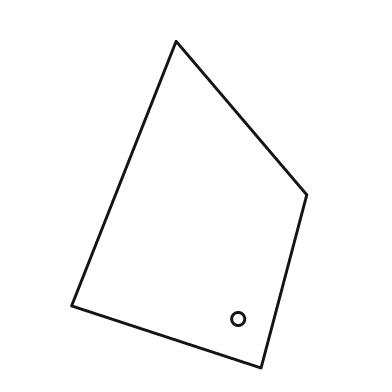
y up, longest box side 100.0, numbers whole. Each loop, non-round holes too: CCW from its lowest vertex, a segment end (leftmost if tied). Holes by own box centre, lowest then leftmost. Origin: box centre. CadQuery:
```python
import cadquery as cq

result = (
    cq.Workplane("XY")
    .moveTo(22.0, -50.0)
    .lineTo(36.0, 3.0)
    .lineTo(-4.0, 50.0)
    .lineTo(-36.0, -31.0)
    .close()
    .moveTo(15.0, -35.0)
    .circle(2.0)
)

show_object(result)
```